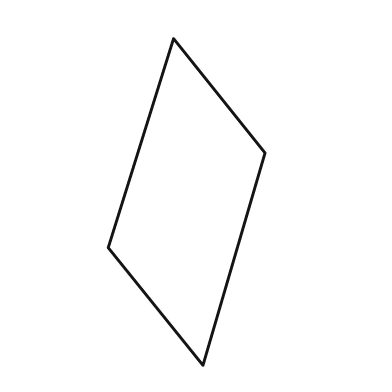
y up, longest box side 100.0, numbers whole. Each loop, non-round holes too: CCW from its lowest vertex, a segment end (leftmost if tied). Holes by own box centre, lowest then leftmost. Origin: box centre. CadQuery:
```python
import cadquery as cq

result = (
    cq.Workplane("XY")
    .moveTo(5.0, -50.0)
    .lineTo(24.0, 15.0)
    .lineTo(-4.0, 50.0)
    .lineTo(-24.0, -14.0)
    .close()
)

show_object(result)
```